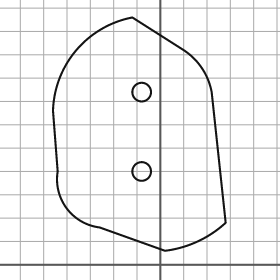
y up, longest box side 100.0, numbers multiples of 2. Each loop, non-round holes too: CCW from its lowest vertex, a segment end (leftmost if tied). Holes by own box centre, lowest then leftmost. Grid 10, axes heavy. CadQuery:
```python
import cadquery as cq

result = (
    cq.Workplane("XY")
    .moveTo(2.0, 6.0)
    .threePointArc((16.0, 10.0), (28.0, 18.0))
    .lineTo(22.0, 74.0)
    .threePointArc((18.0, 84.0), (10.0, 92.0))
    .lineTo(-12.0, 106.0)
    .threePointArc((-36.0, 92.0), (-46.0, 66.0))
    .lineTo(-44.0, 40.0)
    .threePointArc((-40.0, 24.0), (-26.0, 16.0))
    .close()
    .moveTo(-8.0, 40.0)
    .circle(4.0)
    .moveTo(-8.0, 74.0)
    .circle(4.0)
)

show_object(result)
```